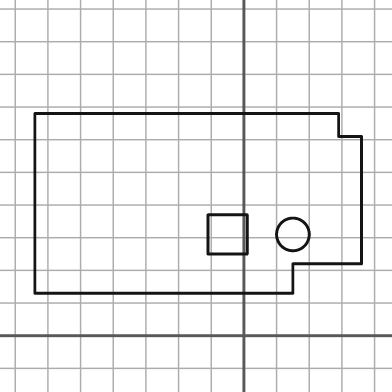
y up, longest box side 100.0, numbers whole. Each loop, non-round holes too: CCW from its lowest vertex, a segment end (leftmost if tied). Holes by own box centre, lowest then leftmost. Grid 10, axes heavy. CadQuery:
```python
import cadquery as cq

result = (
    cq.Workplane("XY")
    .moveTo(-64.0, 13.0)
    .lineTo(15.0, 13.0)
    .lineTo(15.0, 22.0)
    .lineTo(36.0, 22.0)
    .lineTo(36.0, 61.0)
    .lineTo(29.0, 61.0)
    .lineTo(29.0, 68.0)
    .lineTo(-64.0, 68.0)
    .close()
    .moveTo(-11.0, 25.0)
    .lineTo(1.0, 25.0)
    .lineTo(1.0, 37.0)
    .lineTo(-11.0, 37.0)
    .close()
    .moveTo(15.0, 31.0)
    .circle(5.0)
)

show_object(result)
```